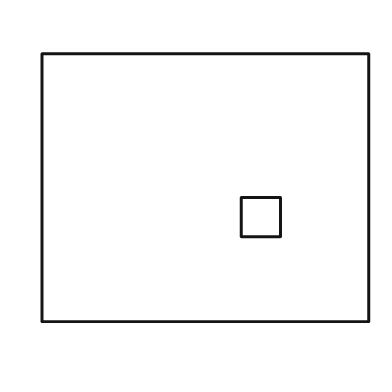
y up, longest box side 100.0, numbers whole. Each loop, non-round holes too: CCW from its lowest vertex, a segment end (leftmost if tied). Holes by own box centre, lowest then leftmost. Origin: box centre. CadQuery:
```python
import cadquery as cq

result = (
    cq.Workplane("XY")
    .moveTo(-50.0, -41.0)
    .lineTo(50.0, -41.0)
    .lineTo(50.0, 41.0)
    .lineTo(-50.0, 41.0)
    .close()
    .moveTo(11.0, -15.0)
    .lineTo(23.0, -15.0)
    .lineTo(23.0, -3.0)
    .lineTo(11.0, -3.0)
    .close()
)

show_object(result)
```